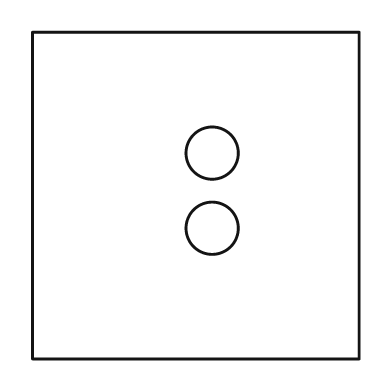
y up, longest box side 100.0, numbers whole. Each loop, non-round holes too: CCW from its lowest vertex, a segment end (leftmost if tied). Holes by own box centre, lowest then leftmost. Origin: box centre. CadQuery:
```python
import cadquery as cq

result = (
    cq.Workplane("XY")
    .moveTo(-50.0, -50.0)
    .lineTo(50.0, -50.0)
    .lineTo(50.0, 50.0)
    .lineTo(-50.0, 50.0)
    .close()
    .moveTo(5.0, -10.0)
    .circle(8.0)
    .moveTo(5.0, 13.0)
    .circle(8.0)
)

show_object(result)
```